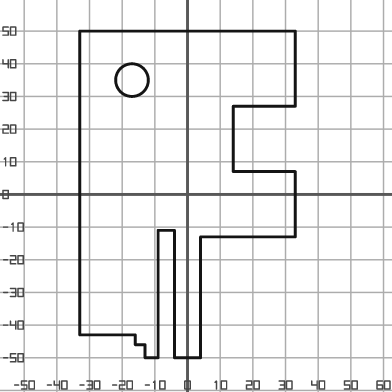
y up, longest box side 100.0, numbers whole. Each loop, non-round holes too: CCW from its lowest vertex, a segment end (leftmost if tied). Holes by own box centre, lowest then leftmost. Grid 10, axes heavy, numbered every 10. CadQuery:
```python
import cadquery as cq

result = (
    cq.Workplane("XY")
    .moveTo(-13.0, -50.0)
    .lineTo(-9.0, -50.0)
    .lineTo(-9.0, -11.0)
    .lineTo(-4.0, -11.0)
    .lineTo(-4.0, -50.0)
    .lineTo(4.0, -50.0)
    .lineTo(4.0, -13.0)
    .lineTo(33.0, -13.0)
    .lineTo(33.0, 7.0)
    .lineTo(14.0, 7.0)
    .lineTo(14.0, 27.0)
    .lineTo(33.0, 27.0)
    .lineTo(33.0, 50.0)
    .lineTo(-33.0, 50.0)
    .lineTo(-33.0, -43.0)
    .lineTo(-16.0, -43.0)
    .lineTo(-16.0, -46.0)
    .lineTo(-13.0, -46.0)
    .close()
    .moveTo(-17.0, 35.0)
    .circle(5.0)
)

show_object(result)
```